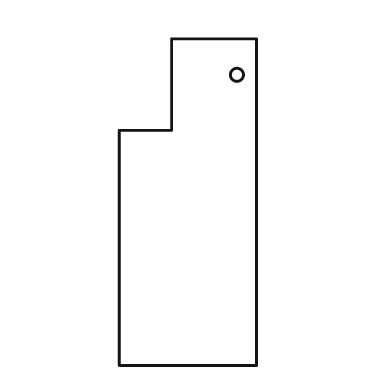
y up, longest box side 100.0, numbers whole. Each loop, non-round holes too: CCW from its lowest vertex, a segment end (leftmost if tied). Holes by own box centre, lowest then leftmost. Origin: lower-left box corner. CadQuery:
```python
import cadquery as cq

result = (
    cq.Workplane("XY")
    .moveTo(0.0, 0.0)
    .lineTo(42.0, 0.0)
    .lineTo(42.0, 100.0)
    .lineTo(16.0, 100.0)
    .lineTo(16.0, 72.0)
    .lineTo(0.0, 72.0)
    .close()
    .moveTo(36.0, 89.0)
    .circle(2.0)
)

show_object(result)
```